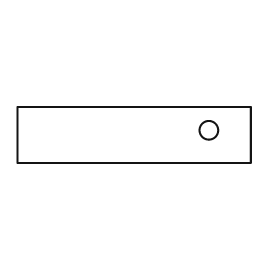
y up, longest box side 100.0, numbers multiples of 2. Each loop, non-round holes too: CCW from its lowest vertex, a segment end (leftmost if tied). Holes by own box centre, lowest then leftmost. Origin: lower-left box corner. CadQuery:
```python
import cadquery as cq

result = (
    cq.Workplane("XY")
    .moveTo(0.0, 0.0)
    .lineTo(100.0, 0.0)
    .lineTo(100.0, 24.0)
    .lineTo(0.0, 24.0)
    .close()
    .moveTo(82.0, 14.0)
    .circle(4.0)
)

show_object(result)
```